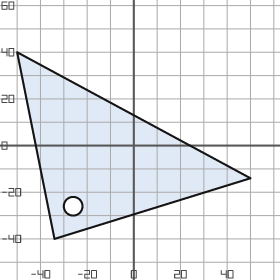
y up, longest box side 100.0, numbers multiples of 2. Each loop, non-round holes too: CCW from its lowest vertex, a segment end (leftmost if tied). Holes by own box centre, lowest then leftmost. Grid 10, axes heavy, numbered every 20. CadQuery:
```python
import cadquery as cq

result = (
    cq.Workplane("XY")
    .moveTo(-34.0, -40.0)
    .lineTo(50.0, -14.0)
    .lineTo(-50.0, 40.0)
    .close()
    .moveTo(-26.0, -26.0)
    .circle(4.0)
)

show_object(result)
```